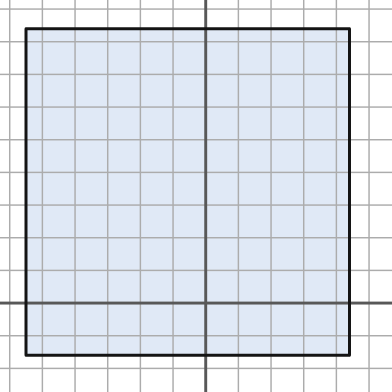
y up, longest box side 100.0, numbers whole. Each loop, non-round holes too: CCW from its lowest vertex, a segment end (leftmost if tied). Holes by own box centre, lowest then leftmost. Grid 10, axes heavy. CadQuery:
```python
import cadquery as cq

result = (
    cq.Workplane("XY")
    .moveTo(-55.0, -16.0)
    .lineTo(44.0, -16.0)
    .lineTo(44.0, 84.0)
    .lineTo(-55.0, 84.0)
    .close()
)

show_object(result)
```